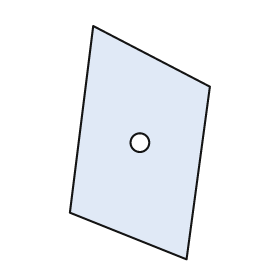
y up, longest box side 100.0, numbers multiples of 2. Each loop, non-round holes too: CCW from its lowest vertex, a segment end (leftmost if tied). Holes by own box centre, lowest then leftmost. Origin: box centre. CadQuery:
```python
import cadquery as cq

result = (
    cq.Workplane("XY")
    .moveTo(20.0, -50.0)
    .lineTo(30.0, 24.0)
    .lineTo(-20.0, 50.0)
    .lineTo(-30.0, -30.0)
    .close()
    .moveTo(0.0, 0.0)
    .circle(4.0)
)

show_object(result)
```